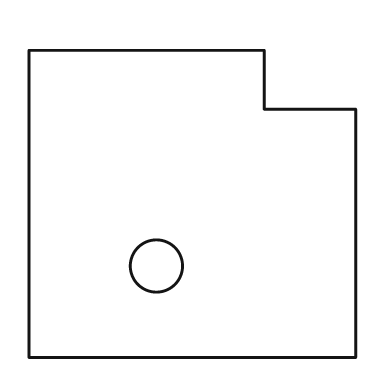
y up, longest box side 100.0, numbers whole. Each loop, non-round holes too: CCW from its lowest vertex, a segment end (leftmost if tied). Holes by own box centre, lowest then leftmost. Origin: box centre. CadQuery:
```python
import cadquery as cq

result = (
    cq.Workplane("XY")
    .moveTo(-50.0, -47.0)
    .lineTo(50.0, -47.0)
    .lineTo(50.0, 29.0)
    .lineTo(22.0, 29.0)
    .lineTo(22.0, 47.0)
    .lineTo(-50.0, 47.0)
    .close()
    .moveTo(-11.0, -19.0)
    .circle(8.0)
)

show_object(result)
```